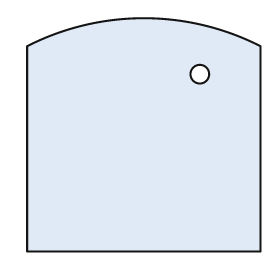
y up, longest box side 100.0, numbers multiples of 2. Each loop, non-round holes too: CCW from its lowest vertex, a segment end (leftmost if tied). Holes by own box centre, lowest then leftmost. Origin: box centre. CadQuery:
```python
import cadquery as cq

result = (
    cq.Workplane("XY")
    .moveTo(-50.0, -50.0)
    .lineTo(50.0, -50.0)
    .lineTo(50.0, 38.0)
    .threePointArc((0.0, 50.0), (-50.0, 38.0))
    .close()
    .moveTo(24.0, 26.0)
    .circle(4.0)
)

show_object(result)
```